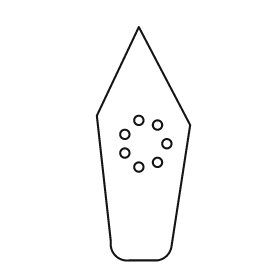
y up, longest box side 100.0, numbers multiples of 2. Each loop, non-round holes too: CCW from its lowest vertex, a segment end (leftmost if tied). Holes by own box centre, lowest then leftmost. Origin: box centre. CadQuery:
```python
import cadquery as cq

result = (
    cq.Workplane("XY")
    .moveTo(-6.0, -50.0)
    .lineTo(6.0, -50.0)
    .threePointArc((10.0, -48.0), (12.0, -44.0))
    .lineTo(20.0, 8.0)
    .lineTo(-2.0, 50.0)
    .lineTo(-20.0, 12.0)
    .lineTo(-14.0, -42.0)
    .threePointArc((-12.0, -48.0), (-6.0, -50.0))
    .close()
    .moveTo(-2.0, -10.0)
    .circle(2.0)
    .moveTo(6.0, -8.0)
    .circle(2.0)
    .moveTo(-8.0, -4.0)
    .circle(2.0)
    .moveTo(10.0, 0.0)
    .circle(2.0)
    .moveTo(-8.0, 4.0)
    .circle(2.0)
    .moveTo(6.0, 8.0)
    .circle(2.0)
    .moveTo(-2.0, 10.0)
    .circle(2.0)
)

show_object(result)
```